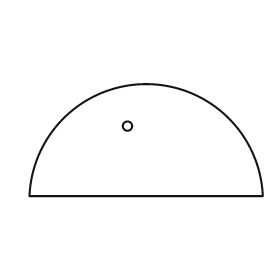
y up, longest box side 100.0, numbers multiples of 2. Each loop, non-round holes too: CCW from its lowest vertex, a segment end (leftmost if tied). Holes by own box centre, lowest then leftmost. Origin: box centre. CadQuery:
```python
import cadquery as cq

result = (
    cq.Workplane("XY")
    .moveTo(-50.0, -24.0)
    .lineTo(50.0, -24.0)
    .threePointArc((0.0, 24.0), (-50.0, -24.0))
    .close()
    .moveTo(-8.0, 6.0)
    .circle(2.0)
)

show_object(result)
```